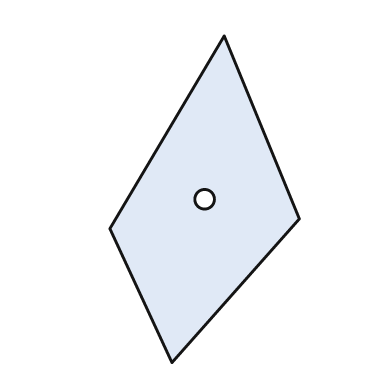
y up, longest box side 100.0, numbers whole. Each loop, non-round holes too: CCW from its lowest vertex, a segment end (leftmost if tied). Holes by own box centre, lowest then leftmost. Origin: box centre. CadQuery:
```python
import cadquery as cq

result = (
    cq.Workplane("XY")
    .moveTo(-10.0, -50.0)
    .lineTo(29.0, -6.0)
    .lineTo(6.0, 50.0)
    .lineTo(-29.0, -9.0)
    .close()
    .moveTo(0.0, 0.0)
    .circle(3.0)
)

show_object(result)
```